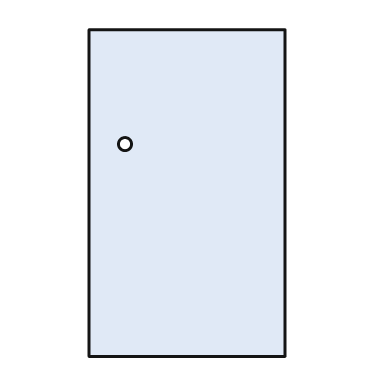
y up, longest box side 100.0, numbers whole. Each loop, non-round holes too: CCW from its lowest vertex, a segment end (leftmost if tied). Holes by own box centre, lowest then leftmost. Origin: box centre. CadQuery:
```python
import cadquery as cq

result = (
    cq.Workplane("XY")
    .moveTo(-30.0, -50.0)
    .lineTo(30.0, -50.0)
    .lineTo(30.0, 50.0)
    .lineTo(-30.0, 50.0)
    .close()
    .moveTo(-19.0, 15.0)
    .circle(2.0)
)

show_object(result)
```